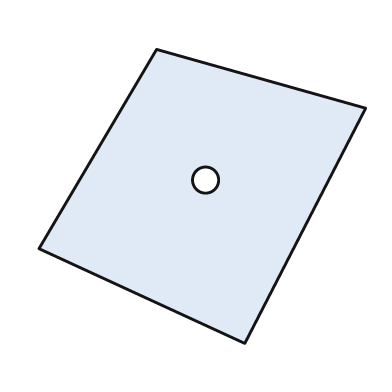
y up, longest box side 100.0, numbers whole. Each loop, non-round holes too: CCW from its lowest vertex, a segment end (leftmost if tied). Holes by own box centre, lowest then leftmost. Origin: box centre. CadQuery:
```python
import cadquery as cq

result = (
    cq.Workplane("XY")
    .moveTo(13.0, -45.0)
    .lineTo(50.0, 27.0)
    .lineTo(-14.0, 45.0)
    .lineTo(-50.0, -16.0)
    .close()
    .moveTo(1.0, 5.0)
    .circle(4.0)
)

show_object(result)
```